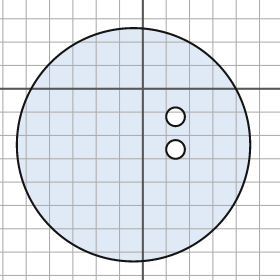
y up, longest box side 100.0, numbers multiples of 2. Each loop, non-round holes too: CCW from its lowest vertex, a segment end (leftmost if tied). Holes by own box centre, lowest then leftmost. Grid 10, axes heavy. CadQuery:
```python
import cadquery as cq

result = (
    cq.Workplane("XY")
    .moveTo(-4.0, -24.0)
    .circle(50.0)
    .moveTo(14.0, -26.0)
    .circle(4.0)
    .moveTo(14.0, -12.0)
    .circle(4.0)
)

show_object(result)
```